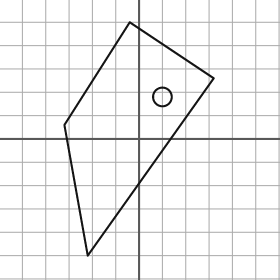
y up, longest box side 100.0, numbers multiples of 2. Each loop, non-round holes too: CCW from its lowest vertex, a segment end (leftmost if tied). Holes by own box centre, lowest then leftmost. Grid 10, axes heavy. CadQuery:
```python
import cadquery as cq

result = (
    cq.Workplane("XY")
    .moveTo(-22.0, -50.0)
    .lineTo(32.0, 26.0)
    .lineTo(-4.0, 50.0)
    .lineTo(-32.0, 6.0)
    .close()
    .moveTo(10.0, 18.0)
    .circle(4.0)
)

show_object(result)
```